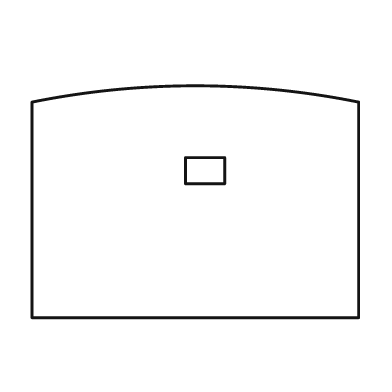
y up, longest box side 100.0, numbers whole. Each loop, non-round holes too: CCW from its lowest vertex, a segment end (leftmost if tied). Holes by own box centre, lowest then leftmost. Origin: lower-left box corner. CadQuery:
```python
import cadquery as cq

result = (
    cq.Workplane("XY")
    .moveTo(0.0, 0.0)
    .lineTo(100.0, 0.0)
    .lineTo(100.0, 66.0)
    .threePointArc((50.0, 71.0), (0.0, 66.0))
    .close()
    .moveTo(47.0, 41.0)
    .lineTo(59.0, 41.0)
    .lineTo(59.0, 49.0)
    .lineTo(47.0, 49.0)
    .close()
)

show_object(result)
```